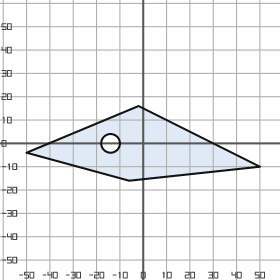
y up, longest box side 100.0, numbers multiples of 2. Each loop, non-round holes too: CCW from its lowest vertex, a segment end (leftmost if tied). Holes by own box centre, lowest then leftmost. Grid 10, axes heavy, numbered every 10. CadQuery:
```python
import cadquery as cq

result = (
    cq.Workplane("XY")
    .moveTo(-6.0, -16.0)
    .lineTo(50.0, -10.0)
    .lineTo(-2.0, 16.0)
    .lineTo(-50.0, -4.0)
    .close()
    .moveTo(-14.0, 0.0)
    .circle(4.0)
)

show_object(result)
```